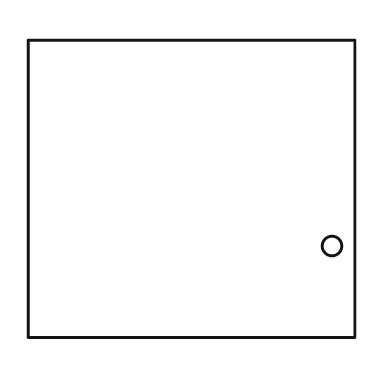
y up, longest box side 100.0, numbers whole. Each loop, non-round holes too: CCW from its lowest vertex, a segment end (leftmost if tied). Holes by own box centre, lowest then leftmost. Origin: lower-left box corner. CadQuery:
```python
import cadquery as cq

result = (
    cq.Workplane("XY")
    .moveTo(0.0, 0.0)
    .lineTo(100.0, 0.0)
    .lineTo(100.0, 91.0)
    .lineTo(0.0, 91.0)
    .close()
    .moveTo(93.0, 28.0)
    .circle(3.0)
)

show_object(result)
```